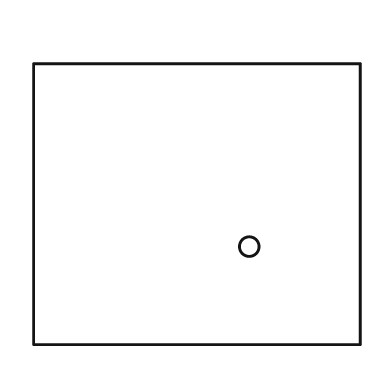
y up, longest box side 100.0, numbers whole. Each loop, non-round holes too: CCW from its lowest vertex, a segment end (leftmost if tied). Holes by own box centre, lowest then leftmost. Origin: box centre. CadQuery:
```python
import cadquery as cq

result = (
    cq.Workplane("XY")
    .moveTo(-50.0, -43.0)
    .lineTo(50.0, -43.0)
    .lineTo(50.0, 43.0)
    .lineTo(-50.0, 43.0)
    .close()
    .moveTo(16.0, -13.0)
    .circle(3.0)
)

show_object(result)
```